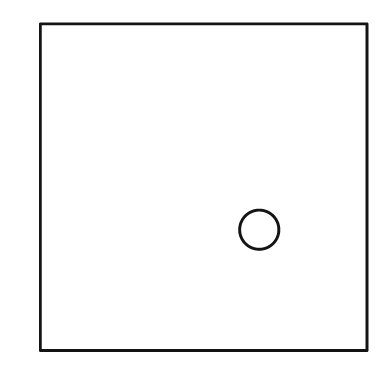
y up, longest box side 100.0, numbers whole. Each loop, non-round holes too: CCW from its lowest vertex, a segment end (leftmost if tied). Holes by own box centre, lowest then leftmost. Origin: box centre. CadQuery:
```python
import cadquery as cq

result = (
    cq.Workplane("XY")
    .moveTo(-50.0, -50.0)
    .lineTo(50.0, -50.0)
    .lineTo(50.0, 50.0)
    .lineTo(-50.0, 50.0)
    .close()
    .moveTo(17.0, -13.0)
    .circle(6.0)
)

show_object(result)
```